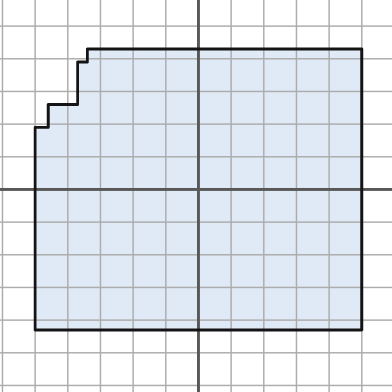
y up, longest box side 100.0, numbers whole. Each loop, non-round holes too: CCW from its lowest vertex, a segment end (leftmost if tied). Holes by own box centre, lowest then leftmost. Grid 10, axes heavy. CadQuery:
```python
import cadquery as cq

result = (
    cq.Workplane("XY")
    .moveTo(-50.0, -43.0)
    .lineTo(50.0, -43.0)
    .lineTo(50.0, 43.0)
    .lineTo(-34.0, 43.0)
    .lineTo(-34.0, 39.0)
    .lineTo(-37.0, 39.0)
    .lineTo(-37.0, 26.0)
    .lineTo(-46.0, 26.0)
    .lineTo(-46.0, 19.0)
    .lineTo(-50.0, 19.0)
    .close()
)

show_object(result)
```